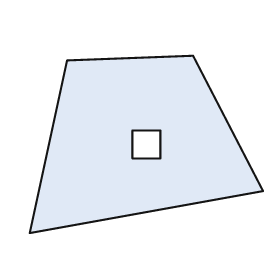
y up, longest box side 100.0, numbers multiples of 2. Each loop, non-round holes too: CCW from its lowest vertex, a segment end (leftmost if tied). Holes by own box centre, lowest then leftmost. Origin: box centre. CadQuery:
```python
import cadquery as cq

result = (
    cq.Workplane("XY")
    .moveTo(-50.0, -38.0)
    .lineTo(50.0, -20.0)
    .lineTo(20.0, 38.0)
    .lineTo(-34.0, 36.0)
    .close()
    .moveTo(-6.0, -6.0)
    .lineTo(6.0, -6.0)
    .lineTo(6.0, 6.0)
    .lineTo(-6.0, 6.0)
    .close()
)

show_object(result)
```